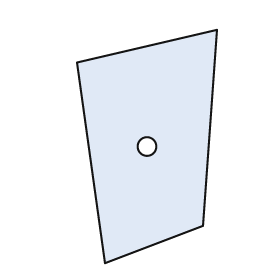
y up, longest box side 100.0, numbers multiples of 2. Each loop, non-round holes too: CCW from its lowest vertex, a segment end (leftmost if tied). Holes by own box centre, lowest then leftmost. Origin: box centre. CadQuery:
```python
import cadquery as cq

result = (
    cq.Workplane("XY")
    .moveTo(-18.0, -50.0)
    .lineTo(24.0, -34.0)
    .lineTo(30.0, 50.0)
    .lineTo(-30.0, 36.0)
    .close()
    .moveTo(0.0, 0.0)
    .circle(4.0)
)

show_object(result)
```